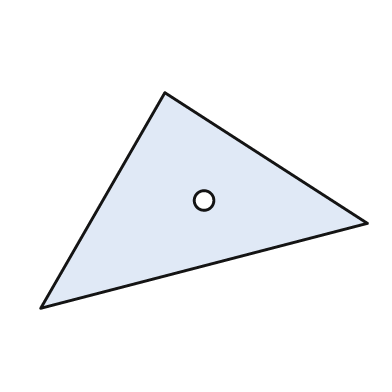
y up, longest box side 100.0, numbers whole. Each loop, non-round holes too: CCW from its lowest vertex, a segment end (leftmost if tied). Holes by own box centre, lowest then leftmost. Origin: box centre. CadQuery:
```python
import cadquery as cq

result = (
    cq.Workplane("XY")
    .moveTo(-50.0, -33.0)
    .lineTo(50.0, -7.0)
    .lineTo(-12.0, 33.0)
    .close()
    .moveTo(0.0, 0.0)
    .circle(3.0)
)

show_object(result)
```